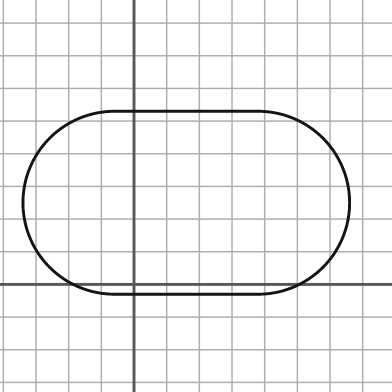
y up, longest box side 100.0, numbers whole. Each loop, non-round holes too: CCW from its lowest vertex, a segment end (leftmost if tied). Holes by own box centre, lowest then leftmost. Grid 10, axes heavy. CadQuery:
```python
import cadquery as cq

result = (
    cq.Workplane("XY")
    .moveTo(-6.0, -3.0)
    .lineTo(38.0, -3.0)
    .threePointArc((66.0, 25.0), (38.0, 53.0))
    .lineTo(-6.0, 53.0)
    .threePointArc((-34.0, 25.0), (-6.0, -3.0))
    .close()
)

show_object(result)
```